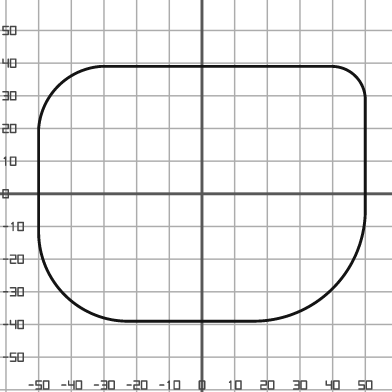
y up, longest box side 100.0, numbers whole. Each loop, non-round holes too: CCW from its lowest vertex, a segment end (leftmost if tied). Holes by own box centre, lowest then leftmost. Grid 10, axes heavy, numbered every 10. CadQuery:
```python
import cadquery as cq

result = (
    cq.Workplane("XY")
    .moveTo(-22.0, -39.0)
    .lineTo(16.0, -39.0)
    .threePointArc((40.0, -29.0), (50.0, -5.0))
    .lineTo(50.0, 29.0)
    .threePointArc((47.0, 36.0), (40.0, 39.0))
    .lineTo(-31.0, 39.0)
    .threePointArc((-44.0, 33.0), (-50.0, 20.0))
    .lineTo(-50.0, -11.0)
    .threePointArc((-42.0, -31.0), (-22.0, -39.0))
    .close()
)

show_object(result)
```